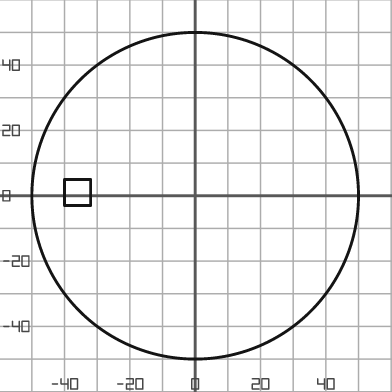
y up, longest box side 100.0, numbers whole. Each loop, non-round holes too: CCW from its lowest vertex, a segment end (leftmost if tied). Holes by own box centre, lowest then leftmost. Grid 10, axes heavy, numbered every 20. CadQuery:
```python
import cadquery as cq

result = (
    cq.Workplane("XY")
    .moveTo(0.0, 0.0)
    .circle(50.0)
    .moveTo(-40.0, -3.0)
    .lineTo(-32.0, -3.0)
    .lineTo(-32.0, 5.0)
    .lineTo(-40.0, 5.0)
    .close()
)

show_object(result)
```